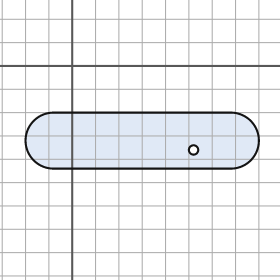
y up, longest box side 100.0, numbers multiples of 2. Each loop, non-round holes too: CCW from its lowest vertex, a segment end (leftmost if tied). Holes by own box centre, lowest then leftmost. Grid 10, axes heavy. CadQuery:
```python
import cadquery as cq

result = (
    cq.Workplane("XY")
    .moveTo(-8.0, -44.0)
    .lineTo(68.0, -44.0)
    .threePointArc((80.0, -32.0), (68.0, -20.0))
    .lineTo(-8.0, -20.0)
    .threePointArc((-20.0, -32.0), (-8.0, -44.0))
    .close()
    .moveTo(52.0, -36.0)
    .circle(2.0)
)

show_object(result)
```